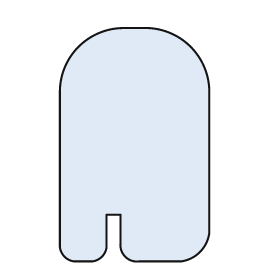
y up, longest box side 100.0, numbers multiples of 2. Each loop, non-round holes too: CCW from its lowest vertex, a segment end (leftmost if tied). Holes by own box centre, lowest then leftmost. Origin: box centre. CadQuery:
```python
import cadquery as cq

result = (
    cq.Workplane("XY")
    .moveTo(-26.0, -50.0)
    .lineTo(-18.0, -50.0)
    .threePointArc((-14.0, -48.0), (-12.0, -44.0))
    .lineTo(-12.0, -30.0)
    .lineTo(-6.0, -30.0)
    .lineTo(-6.0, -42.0)
    .threePointArc((-4.0, -48.0), (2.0, -50.0))
    .lineTo(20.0, -50.0)
    .threePointArc((28.0, -46.0), (32.0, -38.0))
    .lineTo(32.0, 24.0)
    .threePointArc((24.0, 42.0), (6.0, 50.0))
    .lineTo(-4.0, 50.0)
    .threePointArc((-24.0, 42.0), (-32.0, 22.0))
    .lineTo(-32.0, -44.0)
    .threePointArc((-30.0, -48.0), (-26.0, -50.0))
    .close()
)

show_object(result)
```